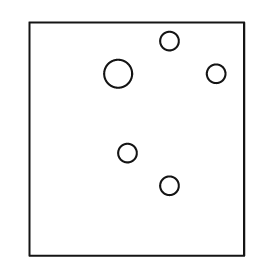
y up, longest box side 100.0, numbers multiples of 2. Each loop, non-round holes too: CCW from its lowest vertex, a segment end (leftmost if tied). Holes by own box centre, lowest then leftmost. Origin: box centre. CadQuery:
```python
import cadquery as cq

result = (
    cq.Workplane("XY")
    .moveTo(-46.0, -50.0)
    .lineTo(46.0, -50.0)
    .lineTo(46.0, 50.0)
    .lineTo(-46.0, 50.0)
    .close()
    .moveTo(14.0, -20.0)
    .circle(4.0)
    .moveTo(-4.0, -6.0)
    .circle(4.0)
    .moveTo(-8.0, 28.0)
    .circle(6.0)
    .moveTo(34.0, 28.0)
    .circle(4.0)
    .moveTo(14.0, 42.0)
    .circle(4.0)
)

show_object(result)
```